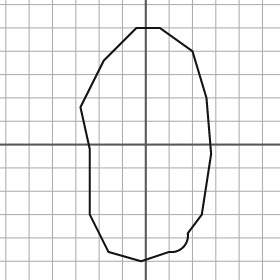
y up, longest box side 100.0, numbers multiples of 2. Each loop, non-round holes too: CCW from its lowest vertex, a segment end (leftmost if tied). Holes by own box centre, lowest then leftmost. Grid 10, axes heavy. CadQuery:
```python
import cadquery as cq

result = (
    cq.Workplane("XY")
    .moveTo(-2.0, -50.0)
    .lineTo(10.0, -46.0)
    .threePointArc((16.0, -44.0), (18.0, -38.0))
    .lineTo(24.0, -30.0)
    .lineTo(28.0, -4.0)
    .lineTo(26.0, 20.0)
    .lineTo(20.0, 40.0)
    .lineTo(6.0, 50.0)
    .lineTo(-4.0, 50.0)
    .lineTo(-18.0, 36.0)
    .lineTo(-28.0, 16.0)
    .lineTo(-24.0, -2.0)
    .lineTo(-24.0, -30.0)
    .lineTo(-16.0, -46.0)
    .close()
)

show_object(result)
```